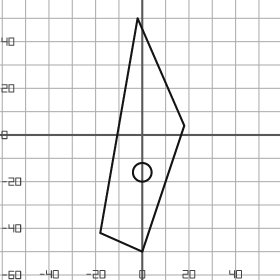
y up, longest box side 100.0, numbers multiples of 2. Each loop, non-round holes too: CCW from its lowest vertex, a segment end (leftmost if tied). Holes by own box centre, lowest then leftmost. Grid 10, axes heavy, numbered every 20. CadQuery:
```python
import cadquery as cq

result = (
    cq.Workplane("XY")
    .moveTo(0.0, -50.0)
    .lineTo(18.0, 4.0)
    .lineTo(-2.0, 50.0)
    .lineTo(-18.0, -42.0)
    .close()
    .moveTo(0.0, -16.0)
    .circle(4.0)
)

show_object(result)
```